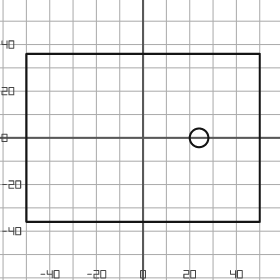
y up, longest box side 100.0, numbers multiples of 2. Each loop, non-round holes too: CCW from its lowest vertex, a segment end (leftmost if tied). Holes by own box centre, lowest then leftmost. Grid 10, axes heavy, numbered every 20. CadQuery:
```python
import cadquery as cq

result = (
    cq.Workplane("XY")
    .moveTo(-50.0, -36.0)
    .lineTo(50.0, -36.0)
    .lineTo(50.0, 36.0)
    .lineTo(-50.0, 36.0)
    .close()
    .moveTo(24.0, 0.0)
    .circle(4.0)
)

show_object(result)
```